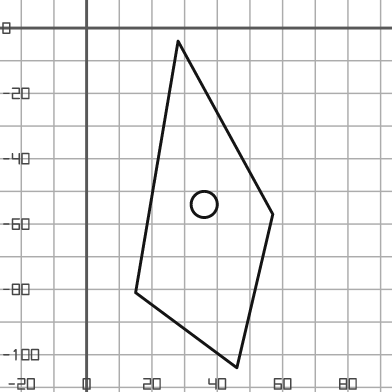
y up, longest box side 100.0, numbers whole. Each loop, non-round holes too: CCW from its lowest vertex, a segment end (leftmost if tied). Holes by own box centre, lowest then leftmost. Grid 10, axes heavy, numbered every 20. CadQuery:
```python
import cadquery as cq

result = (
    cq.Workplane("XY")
    .moveTo(46.0, -104.0)
    .lineTo(57.0, -57.0)
    .lineTo(28.0, -4.0)
    .lineTo(15.0, -81.0)
    .close()
    .moveTo(36.0, -54.0)
    .circle(4.0)
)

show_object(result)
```